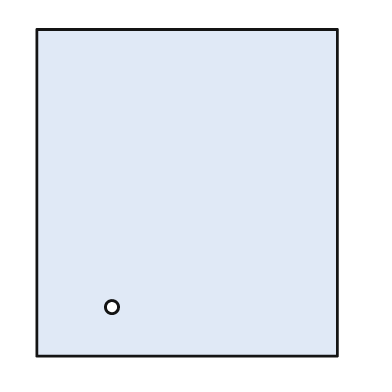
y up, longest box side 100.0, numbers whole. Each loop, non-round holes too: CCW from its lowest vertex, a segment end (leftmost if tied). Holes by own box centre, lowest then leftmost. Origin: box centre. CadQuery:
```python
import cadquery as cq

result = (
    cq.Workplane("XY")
    .moveTo(-46.0, -50.0)
    .lineTo(46.0, -50.0)
    .lineTo(46.0, 50.0)
    .lineTo(-46.0, 50.0)
    .close()
    .moveTo(-23.0, -35.0)
    .circle(2.0)
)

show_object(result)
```